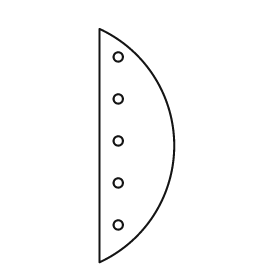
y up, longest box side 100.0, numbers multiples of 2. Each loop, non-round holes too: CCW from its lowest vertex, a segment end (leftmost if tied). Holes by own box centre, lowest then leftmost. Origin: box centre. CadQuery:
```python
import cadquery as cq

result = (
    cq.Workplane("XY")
    .moveTo(-16.0, -50.0)
    .threePointArc((16.0, 0.0), (-16.0, 50.0))
    .close()
    .moveTo(-8.0, -34.0)
    .circle(2.0)
    .moveTo(-8.0, -16.0)
    .circle(2.0)
    .moveTo(-8.0, 2.0)
    .circle(2.0)
    .moveTo(-8.0, 20.0)
    .circle(2.0)
    .moveTo(-8.0, 38.0)
    .circle(2.0)
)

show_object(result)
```